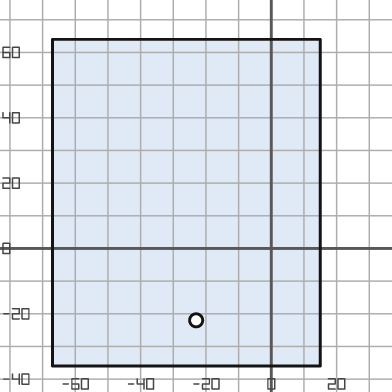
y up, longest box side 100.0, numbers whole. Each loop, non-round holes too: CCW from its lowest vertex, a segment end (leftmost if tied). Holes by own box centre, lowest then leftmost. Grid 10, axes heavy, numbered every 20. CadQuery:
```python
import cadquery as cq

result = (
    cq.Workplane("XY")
    .moveTo(-67.0, -36.0)
    .lineTo(15.0, -36.0)
    .lineTo(15.0, 64.0)
    .lineTo(-67.0, 64.0)
    .close()
    .moveTo(-23.0, -22.0)
    .circle(2.0)
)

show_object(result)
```